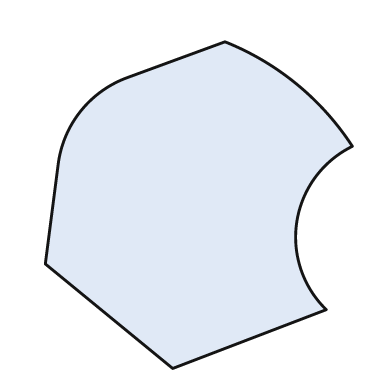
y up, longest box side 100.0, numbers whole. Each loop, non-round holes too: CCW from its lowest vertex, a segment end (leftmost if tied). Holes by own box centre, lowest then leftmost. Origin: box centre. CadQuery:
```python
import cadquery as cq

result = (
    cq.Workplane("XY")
    .moveTo(-8.0, -50.0)
    .lineTo(39.0, -32.0)
    .threePointArc((30.0, -5.0), (47.0, 18.0))
    .threePointArc((30.0, 37.0), (8.0, 50.0))
    .lineTo(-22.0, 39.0)
    .threePointArc((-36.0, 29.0), (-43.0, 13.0))
    .lineTo(-47.0, -18.0)
    .close()
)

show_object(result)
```